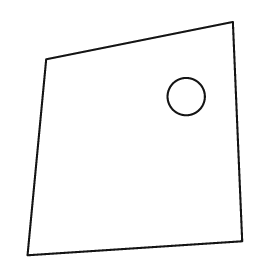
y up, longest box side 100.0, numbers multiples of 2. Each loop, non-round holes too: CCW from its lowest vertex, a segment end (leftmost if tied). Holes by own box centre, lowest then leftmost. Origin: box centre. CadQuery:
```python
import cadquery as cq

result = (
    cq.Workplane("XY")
    .moveTo(-46.0, -50.0)
    .lineTo(46.0, -44.0)
    .lineTo(42.0, 50.0)
    .lineTo(-38.0, 34.0)
    .close()
    .moveTo(22.0, 18.0)
    .circle(8.0)
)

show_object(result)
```